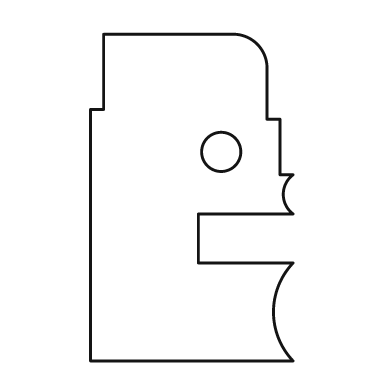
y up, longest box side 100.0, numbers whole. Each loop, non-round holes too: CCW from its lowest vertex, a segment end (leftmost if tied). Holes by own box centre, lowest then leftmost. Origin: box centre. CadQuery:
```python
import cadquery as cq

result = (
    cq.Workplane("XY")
    .moveTo(-31.0, -50.0)
    .lineTo(31.0, -50.0)
    .threePointArc((25.0, -35.0), (31.0, -20.0))
    .lineTo(2.0, -20.0)
    .lineTo(2.0, -5.0)
    .lineTo(31.0, -5.0)
    .threePointArc((28.0, 1.0), (31.0, 7.0))
    .lineTo(27.0, 7.0)
    .lineTo(27.0, 24.0)
    .lineTo(23.0, 24.0)
    .lineTo(23.0, 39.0)
    .threePointArc((20.0, 47.0), (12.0, 50.0))
    .lineTo(-27.0, 50.0)
    .lineTo(-27.0, 27.0)
    .lineTo(-31.0, 27.0)
    .close()
    .moveTo(9.0, 14.0)
    .circle(6.0)
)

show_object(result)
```